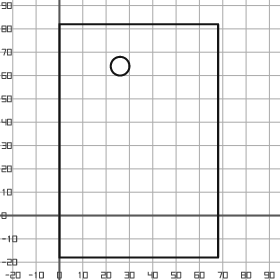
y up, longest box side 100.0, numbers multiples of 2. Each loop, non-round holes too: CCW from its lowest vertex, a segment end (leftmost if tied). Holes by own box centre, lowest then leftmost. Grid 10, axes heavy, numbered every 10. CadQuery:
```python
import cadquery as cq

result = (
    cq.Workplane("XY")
    .moveTo(0.0, -18.0)
    .lineTo(68.0, -18.0)
    .lineTo(68.0, 82.0)
    .lineTo(0.0, 82.0)
    .close()
    .moveTo(26.0, 64.0)
    .circle(4.0)
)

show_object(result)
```